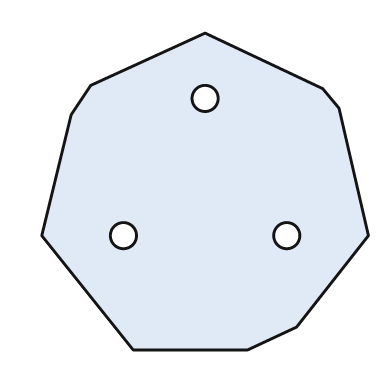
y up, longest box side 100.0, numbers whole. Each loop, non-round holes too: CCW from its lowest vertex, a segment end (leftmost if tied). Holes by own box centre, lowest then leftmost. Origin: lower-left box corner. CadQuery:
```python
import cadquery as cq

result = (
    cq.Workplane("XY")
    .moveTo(28.0, 0.0)
    .lineTo(63.0, 0.0)
    .lineTo(78.0, 7.0)
    .lineTo(100.0, 35.0)
    .lineTo(91.0, 74.0)
    .lineTo(86.0, 80.0)
    .lineTo(50.0, 97.0)
    .lineTo(15.0, 81.0)
    .lineTo(9.0, 72.0)
    .lineTo(0.0, 35.0)
    .close()
    .moveTo(25.0, 35.0)
    .circle(4.0)
    .moveTo(75.0, 35.0)
    .circle(4.0)
    .moveTo(50.0, 77.0)
    .circle(4.0)
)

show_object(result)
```